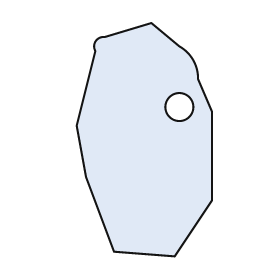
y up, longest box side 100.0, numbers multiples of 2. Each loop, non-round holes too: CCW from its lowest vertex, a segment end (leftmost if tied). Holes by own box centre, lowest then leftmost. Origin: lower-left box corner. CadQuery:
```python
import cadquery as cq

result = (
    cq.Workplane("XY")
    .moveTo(42.0, 0.0)
    .lineTo(58.0, 24.0)
    .lineTo(58.0, 62.0)
    .lineTo(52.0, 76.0)
    .threePointArc((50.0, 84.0), (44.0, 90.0))
    .lineTo(32.0, 100.0)
    .lineTo(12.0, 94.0)
    .threePointArc((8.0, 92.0), (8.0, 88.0))
    .lineTo(0.0, 56.0)
    .lineTo(4.0, 34.0)
    .lineTo(16.0, 2.0)
    .close()
    .moveTo(44.0, 64.0)
    .circle(6.0)
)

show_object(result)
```